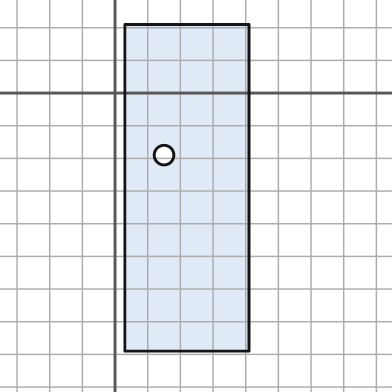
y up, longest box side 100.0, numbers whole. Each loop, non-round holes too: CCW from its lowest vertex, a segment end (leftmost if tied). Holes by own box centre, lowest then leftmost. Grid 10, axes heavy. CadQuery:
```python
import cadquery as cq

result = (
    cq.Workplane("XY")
    .moveTo(3.0, -79.0)
    .lineTo(41.0, -79.0)
    .lineTo(41.0, 21.0)
    .lineTo(3.0, 21.0)
    .close()
    .moveTo(15.0, -19.0)
    .circle(3.0)
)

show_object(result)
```